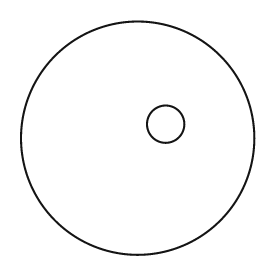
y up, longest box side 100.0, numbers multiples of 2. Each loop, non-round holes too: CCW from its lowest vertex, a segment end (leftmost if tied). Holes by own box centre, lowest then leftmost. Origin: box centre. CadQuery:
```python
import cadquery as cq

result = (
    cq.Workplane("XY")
    .moveTo(0.0, 0.0)
    .circle(50.0)
    .moveTo(12.0, 6.0)
    .circle(8.0)
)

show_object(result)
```